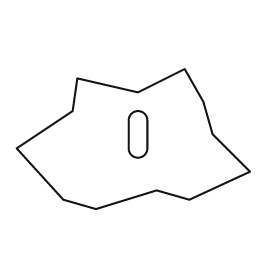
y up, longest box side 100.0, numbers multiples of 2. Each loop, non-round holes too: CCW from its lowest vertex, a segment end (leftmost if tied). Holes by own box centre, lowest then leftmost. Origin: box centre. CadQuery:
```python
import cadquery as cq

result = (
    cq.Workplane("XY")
    .moveTo(-16.0, -30.0)
    .lineTo(10.0, -22.0)
    .lineTo(24.0, -26.0)
    .lineTo(50.0, -14.0)
    .lineTo(34.0, 2.0)
    .lineTo(30.0, 16.0)
    .lineTo(22.0, 30.0)
    .lineTo(2.0, 20.0)
    .lineTo(-24.0, 26.0)
    .lineTo(-26.0, 12.0)
    .lineTo(-50.0, -4.0)
    .lineTo(-30.0, -26.0)
    .close()
    .moveTo(-2.0, -4.0)
    .threePointArc((2.0, -8.0), (6.0, -4.0))
    .lineTo(6.0, 8.0)
    .threePointArc((2.0, 12.0), (-2.0, 8.0))
    .close()
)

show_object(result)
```